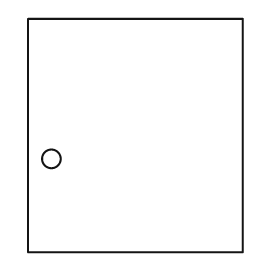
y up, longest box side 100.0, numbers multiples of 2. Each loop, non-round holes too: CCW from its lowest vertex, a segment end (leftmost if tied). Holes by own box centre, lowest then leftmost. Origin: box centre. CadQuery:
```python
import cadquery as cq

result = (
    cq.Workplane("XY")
    .moveTo(-46.0, -50.0)
    .lineTo(46.0, -50.0)
    .lineTo(46.0, 50.0)
    .lineTo(-46.0, 50.0)
    .close()
    .moveTo(-36.0, -10.0)
    .circle(4.0)
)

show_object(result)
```